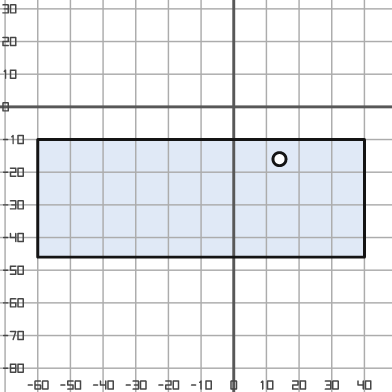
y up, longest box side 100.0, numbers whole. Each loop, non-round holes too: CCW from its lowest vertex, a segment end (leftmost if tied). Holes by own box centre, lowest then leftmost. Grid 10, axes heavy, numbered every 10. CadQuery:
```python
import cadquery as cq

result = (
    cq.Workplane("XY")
    .moveTo(-60.0, -46.0)
    .lineTo(40.0, -46.0)
    .lineTo(40.0, -10.0)
    .lineTo(-60.0, -10.0)
    .close()
    .moveTo(14.0, -16.0)
    .circle(2.0)
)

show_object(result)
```